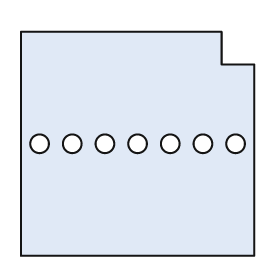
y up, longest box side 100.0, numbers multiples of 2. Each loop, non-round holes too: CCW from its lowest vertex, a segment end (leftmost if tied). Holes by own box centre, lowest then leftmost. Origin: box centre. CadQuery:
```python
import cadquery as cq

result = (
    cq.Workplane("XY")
    .moveTo(-50.0, -48.0)
    .lineTo(50.0, -48.0)
    .lineTo(50.0, 34.0)
    .lineTo(36.0, 34.0)
    .lineTo(36.0, 48.0)
    .lineTo(-50.0, 48.0)
    .close()
    .moveTo(-42.0, 0.0)
    .circle(4.0)
    .moveTo(-28.0, 0.0)
    .circle(4.0)
    .moveTo(-14.0, 0.0)
    .circle(4.0)
    .moveTo(0.0, 0.0)
    .circle(4.0)
    .moveTo(14.0, 0.0)
    .circle(4.0)
    .moveTo(28.0, 0.0)
    .circle(4.0)
    .moveTo(42.0, 0.0)
    .circle(4.0)
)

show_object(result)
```